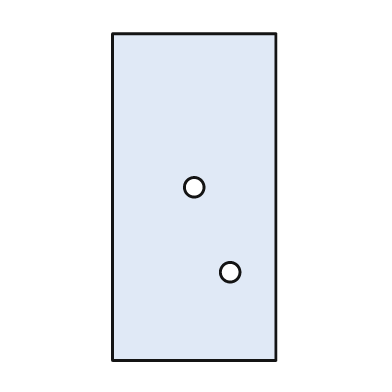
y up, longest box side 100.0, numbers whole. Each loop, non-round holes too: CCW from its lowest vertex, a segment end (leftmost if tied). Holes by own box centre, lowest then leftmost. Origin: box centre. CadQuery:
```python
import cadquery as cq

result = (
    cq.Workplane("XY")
    .moveTo(-25.0, -50.0)
    .lineTo(25.0, -50.0)
    .lineTo(25.0, 50.0)
    .lineTo(-25.0, 50.0)
    .close()
    .moveTo(11.0, -23.0)
    .circle(3.0)
    .moveTo(0.0, 3.0)
    .circle(3.0)
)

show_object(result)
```